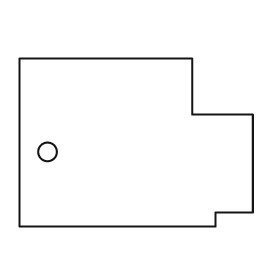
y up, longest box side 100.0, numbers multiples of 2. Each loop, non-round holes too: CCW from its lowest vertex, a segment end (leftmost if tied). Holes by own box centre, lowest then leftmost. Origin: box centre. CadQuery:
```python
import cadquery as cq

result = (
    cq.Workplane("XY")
    .moveTo(-50.0, -36.0)
    .lineTo(34.0, -36.0)
    .lineTo(34.0, -30.0)
    .lineTo(50.0, -30.0)
    .lineTo(50.0, 12.0)
    .lineTo(24.0, 12.0)
    .lineTo(24.0, 36.0)
    .lineTo(-50.0, 36.0)
    .close()
    .moveTo(-38.0, -4.0)
    .circle(4.0)
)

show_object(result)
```